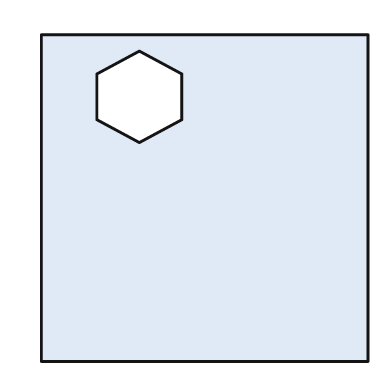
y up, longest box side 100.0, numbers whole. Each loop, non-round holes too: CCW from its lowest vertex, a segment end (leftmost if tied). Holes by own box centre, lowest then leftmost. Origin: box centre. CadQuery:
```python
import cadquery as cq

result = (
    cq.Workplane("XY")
    .moveTo(-50.0, -50.0)
    .lineTo(50.0, -50.0)
    .lineTo(50.0, 50.0)
    .lineTo(-50.0, 50.0)
    .close()
    .moveTo(-20.0, 17.0)
    .lineTo(-7.0, 24.0)
    .lineTo(-7.0, 38.0)
    .lineTo(-20.0, 45.0)
    .lineTo(-33.0, 38.0)
    .lineTo(-33.0, 24.0)
    .close()
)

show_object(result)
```